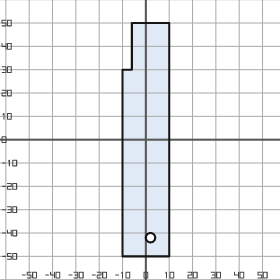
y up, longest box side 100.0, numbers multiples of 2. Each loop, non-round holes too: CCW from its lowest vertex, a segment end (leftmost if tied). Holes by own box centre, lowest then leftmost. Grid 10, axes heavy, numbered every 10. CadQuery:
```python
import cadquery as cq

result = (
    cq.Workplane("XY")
    .moveTo(-10.0, -50.0)
    .lineTo(10.0, -50.0)
    .lineTo(10.0, 50.0)
    .lineTo(-6.0, 50.0)
    .lineTo(-6.0, 30.0)
    .lineTo(-10.0, 30.0)
    .close()
    .moveTo(2.0, -42.0)
    .circle(2.0)
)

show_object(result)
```